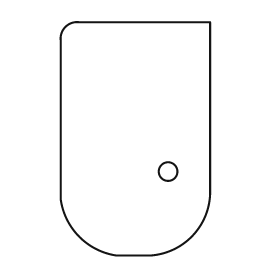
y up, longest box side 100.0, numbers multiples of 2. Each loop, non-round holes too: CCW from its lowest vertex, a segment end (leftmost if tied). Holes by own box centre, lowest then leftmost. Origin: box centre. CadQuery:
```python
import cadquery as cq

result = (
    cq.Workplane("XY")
    .moveTo(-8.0, -50.0)
    .lineTo(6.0, -50.0)
    .threePointArc((24.0, -42.0), (32.0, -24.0))
    .lineTo(32.0, 50.0)
    .lineTo(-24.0, 50.0)
    .threePointArc((-30.0, 48.0), (-32.0, 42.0))
    .lineTo(-32.0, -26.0)
    .threePointArc((-24.0, -42.0), (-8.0, -50.0))
    .close()
    .moveTo(14.0, -14.0)
    .circle(4.0)
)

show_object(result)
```